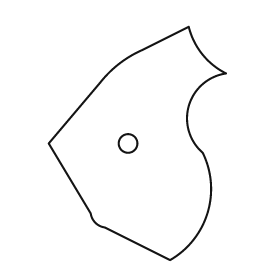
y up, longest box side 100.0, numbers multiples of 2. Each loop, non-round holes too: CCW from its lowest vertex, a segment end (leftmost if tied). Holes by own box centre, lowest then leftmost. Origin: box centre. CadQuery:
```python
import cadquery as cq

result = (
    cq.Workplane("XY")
    .moveTo(14.0, -50.0)
    .threePointArc((30.0, -30.0), (28.0, -4.0))
    .threePointArc((22.0, 16.0), (38.0, 30.0))
    .threePointArc((28.0, 38.0), (22.0, 50.0))
    .lineTo(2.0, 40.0)
    .threePointArc((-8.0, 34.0), (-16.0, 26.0))
    .lineTo(-38.0, 0.0)
    .lineTo(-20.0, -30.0)
    .threePointArc((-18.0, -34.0), (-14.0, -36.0))
    .close()
    .moveTo(-4.0, 0.0)
    .circle(4.0)
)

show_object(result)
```